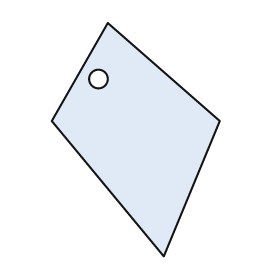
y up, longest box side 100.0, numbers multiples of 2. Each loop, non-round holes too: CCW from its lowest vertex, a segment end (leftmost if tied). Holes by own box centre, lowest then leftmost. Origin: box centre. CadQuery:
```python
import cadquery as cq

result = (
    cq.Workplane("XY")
    .moveTo(12.0, -50.0)
    .lineTo(36.0, 8.0)
    .lineTo(-12.0, 50.0)
    .lineTo(-36.0, 8.0)
    .close()
    .moveTo(-16.0, 26.0)
    .circle(4.0)
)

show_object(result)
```